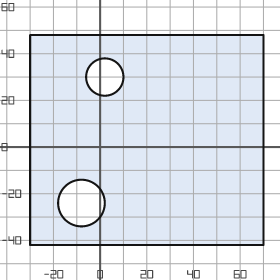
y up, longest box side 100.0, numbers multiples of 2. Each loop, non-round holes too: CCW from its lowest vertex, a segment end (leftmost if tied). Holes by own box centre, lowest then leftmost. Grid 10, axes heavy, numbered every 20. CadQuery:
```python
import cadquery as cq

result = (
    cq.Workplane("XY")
    .moveTo(-30.0, -42.0)
    .lineTo(70.0, -42.0)
    .lineTo(70.0, 48.0)
    .lineTo(-30.0, 48.0)
    .close()
    .moveTo(-8.0, -24.0)
    .circle(10.0)
    .moveTo(2.0, 30.0)
    .circle(8.0)
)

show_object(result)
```